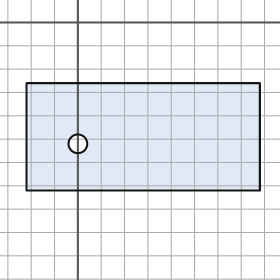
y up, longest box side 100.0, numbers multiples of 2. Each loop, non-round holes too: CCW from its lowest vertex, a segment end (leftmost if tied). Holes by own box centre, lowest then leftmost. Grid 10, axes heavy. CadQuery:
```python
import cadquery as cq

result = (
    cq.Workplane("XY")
    .moveTo(-22.0, -72.0)
    .lineTo(78.0, -72.0)
    .lineTo(78.0, -26.0)
    .lineTo(-22.0, -26.0)
    .close()
    .moveTo(0.0, -52.0)
    .circle(4.0)
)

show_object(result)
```